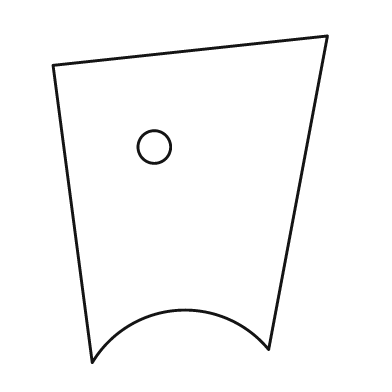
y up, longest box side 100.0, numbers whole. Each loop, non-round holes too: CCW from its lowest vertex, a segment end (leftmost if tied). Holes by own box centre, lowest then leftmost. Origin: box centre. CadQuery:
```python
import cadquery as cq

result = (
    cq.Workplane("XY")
    .moveTo(-30.0, -50.0)
    .threePointArc((-4.0, -34.0), (24.0, -46.0))
    .lineTo(42.0, 50.0)
    .lineTo(-42.0, 41.0)
    .close()
    .moveTo(-11.0, 16.0)
    .circle(5.0)
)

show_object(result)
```